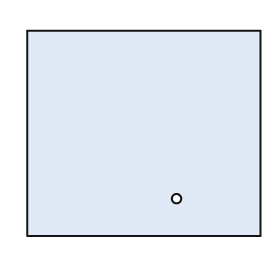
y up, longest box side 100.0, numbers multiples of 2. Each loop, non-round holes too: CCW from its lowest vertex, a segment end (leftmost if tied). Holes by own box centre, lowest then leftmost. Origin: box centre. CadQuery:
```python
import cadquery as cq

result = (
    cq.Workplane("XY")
    .moveTo(-50.0, -44.0)
    .lineTo(50.0, -44.0)
    .lineTo(50.0, 44.0)
    .lineTo(-50.0, 44.0)
    .close()
    .moveTo(14.0, -28.0)
    .circle(2.0)
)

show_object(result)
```